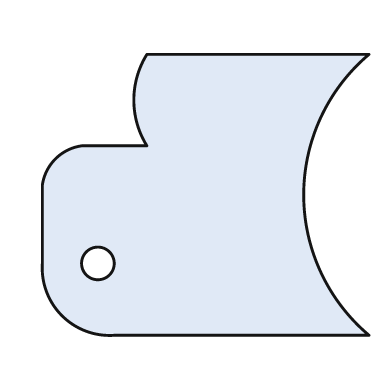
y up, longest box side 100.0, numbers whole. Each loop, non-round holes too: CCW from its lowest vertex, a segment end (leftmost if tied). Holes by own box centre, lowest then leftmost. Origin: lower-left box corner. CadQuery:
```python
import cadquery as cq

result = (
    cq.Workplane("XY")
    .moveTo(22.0, 0.0)
    .lineTo(100.0, 0.0)
    .threePointArc((80.0, 43.0), (100.0, 86.0))
    .lineTo(32.0, 86.0)
    .threePointArc((28.0, 72.0), (32.0, 58.0))
    .lineTo(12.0, 58.0)
    .threePointArc((4.0, 54.0), (0.0, 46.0))
    .lineTo(0.0, 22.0)
    .threePointArc((6.0, 6.0), (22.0, 0.0))
    .close()
    .moveTo(17.0, 22.0)
    .circle(5.0)
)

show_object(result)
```